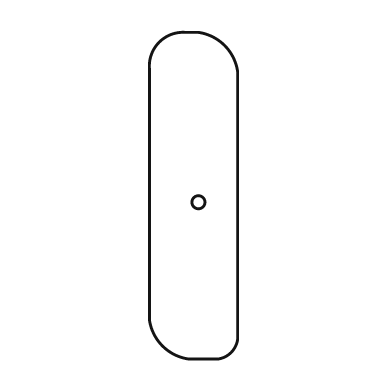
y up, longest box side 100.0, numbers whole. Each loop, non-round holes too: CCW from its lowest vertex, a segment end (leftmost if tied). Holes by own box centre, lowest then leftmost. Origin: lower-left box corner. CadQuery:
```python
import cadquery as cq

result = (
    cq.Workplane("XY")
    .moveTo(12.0, 0.0)
    .lineTo(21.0, 0.0)
    .threePointArc((25.0, 2.0), (27.0, 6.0))
    .lineTo(27.0, 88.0)
    .threePointArc((23.0, 96.0), (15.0, 100.0))
    .lineTo(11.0, 100.0)
    .threePointArc((3.0, 97.0), (0.0, 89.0))
    .lineTo(0.0, 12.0)
    .threePointArc((4.0, 4.0), (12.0, 0.0))
    .close()
    .moveTo(15.0, 48.0)
    .circle(2.0)
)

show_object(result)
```